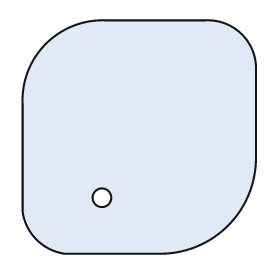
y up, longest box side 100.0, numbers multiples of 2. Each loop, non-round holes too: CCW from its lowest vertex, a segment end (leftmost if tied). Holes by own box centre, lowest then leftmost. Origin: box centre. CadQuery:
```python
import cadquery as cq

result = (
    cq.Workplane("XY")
    .moveTo(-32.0, -50.0)
    .lineTo(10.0, -50.0)
    .threePointArc((38.0, -38.0), (50.0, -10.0))
    .lineTo(50.0, 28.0)
    .threePointArc((44.0, 44.0), (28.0, 50.0))
    .lineTo(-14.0, 50.0)
    .threePointArc((-40.0, 40.0), (-50.0, 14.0))
    .lineTo(-50.0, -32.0)
    .threePointArc((-44.0, -44.0), (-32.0, -50.0))
    .close()
    .moveTo(-16.0, -26.0)
    .circle(4.0)
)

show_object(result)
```